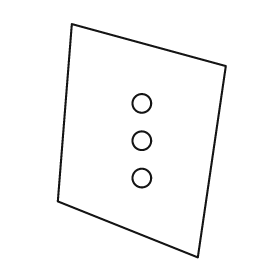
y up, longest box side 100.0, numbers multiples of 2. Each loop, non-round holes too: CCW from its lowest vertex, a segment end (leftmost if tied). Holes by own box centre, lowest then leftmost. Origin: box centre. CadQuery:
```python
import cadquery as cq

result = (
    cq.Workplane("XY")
    .moveTo(24.0, -50.0)
    .lineTo(36.0, 32.0)
    .lineTo(-30.0, 50.0)
    .lineTo(-36.0, -26.0)
    .close()
    .moveTo(0.0, -16.0)
    .circle(4.0)
    .moveTo(0.0, 0.0)
    .circle(4.0)
    .moveTo(0.0, 16.0)
    .circle(4.0)
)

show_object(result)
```